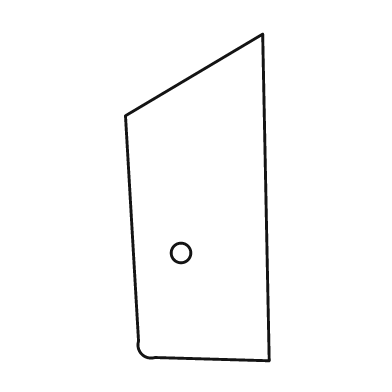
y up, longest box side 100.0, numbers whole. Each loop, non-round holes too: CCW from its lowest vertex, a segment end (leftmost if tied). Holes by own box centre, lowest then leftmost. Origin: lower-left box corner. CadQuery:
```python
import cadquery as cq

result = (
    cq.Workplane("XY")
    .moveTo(44.0, 0.0)
    .lineTo(42.0, 100.0)
    .lineTo(0.0, 75.0)
    .lineTo(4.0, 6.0)
    .threePointArc((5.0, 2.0), (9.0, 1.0))
    .close()
    .moveTo(17.0, 33.0)
    .circle(3.0)
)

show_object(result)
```